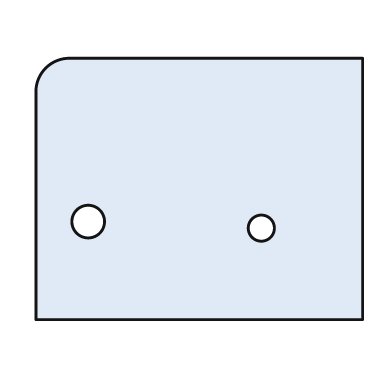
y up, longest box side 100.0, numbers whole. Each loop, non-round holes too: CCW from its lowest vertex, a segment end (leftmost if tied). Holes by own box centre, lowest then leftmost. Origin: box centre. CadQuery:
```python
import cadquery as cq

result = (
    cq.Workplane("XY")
    .moveTo(-50.0, -40.0)
    .lineTo(50.0, -40.0)
    .lineTo(50.0, 40.0)
    .lineTo(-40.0, 40.0)
    .threePointArc((-47.0, 37.0), (-50.0, 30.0))
    .close()
    .moveTo(19.0, -12.0)
    .circle(4.0)
    .moveTo(-34.0, -10.0)
    .circle(5.0)
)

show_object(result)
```